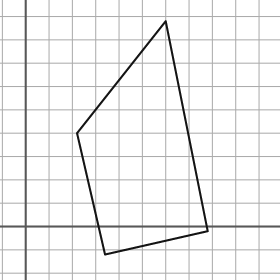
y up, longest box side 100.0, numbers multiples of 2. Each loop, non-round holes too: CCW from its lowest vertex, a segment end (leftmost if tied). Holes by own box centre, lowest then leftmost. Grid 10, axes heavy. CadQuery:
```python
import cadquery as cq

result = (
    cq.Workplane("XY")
    .moveTo(34.0, -12.0)
    .lineTo(78.0, -2.0)
    .lineTo(60.0, 88.0)
    .lineTo(22.0, 40.0)
    .close()
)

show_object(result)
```